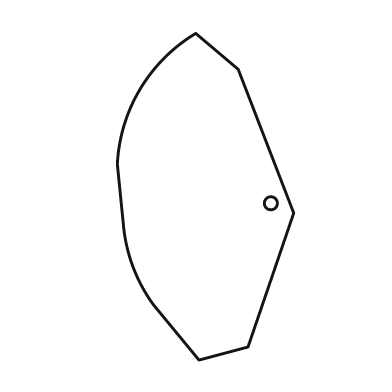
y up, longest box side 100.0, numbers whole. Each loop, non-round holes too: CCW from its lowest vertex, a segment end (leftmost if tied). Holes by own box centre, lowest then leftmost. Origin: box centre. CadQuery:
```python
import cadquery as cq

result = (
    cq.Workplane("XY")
    .moveTo(-2.0, -50.0)
    .lineTo(13.0, -46.0)
    .lineTo(27.0, -5.0)
    .lineTo(10.0, 39.0)
    .lineTo(-3.0, 50.0)
    .threePointArc((-20.0, 33.0), (-27.0, 10.0))
    .lineTo(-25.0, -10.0)
    .threePointArc((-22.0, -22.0), (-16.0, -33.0))
    .close()
    .moveTo(20.0, -2.0)
    .circle(2.0)
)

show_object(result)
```